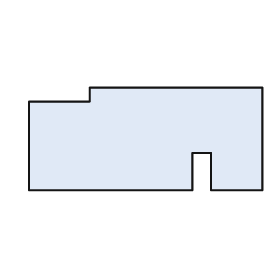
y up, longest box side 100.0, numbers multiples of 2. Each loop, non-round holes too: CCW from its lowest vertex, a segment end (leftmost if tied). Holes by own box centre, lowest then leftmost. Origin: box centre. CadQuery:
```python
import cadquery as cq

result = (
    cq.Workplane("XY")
    .moveTo(-50.0, -22.0)
    .lineTo(20.0, -22.0)
    .lineTo(20.0, -6.0)
    .lineTo(28.0, -6.0)
    .lineTo(28.0, -22.0)
    .lineTo(50.0, -22.0)
    .lineTo(50.0, 22.0)
    .lineTo(-24.0, 22.0)
    .lineTo(-24.0, 16.0)
    .lineTo(-50.0, 16.0)
    .close()
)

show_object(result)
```